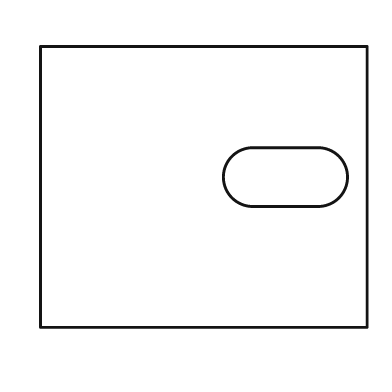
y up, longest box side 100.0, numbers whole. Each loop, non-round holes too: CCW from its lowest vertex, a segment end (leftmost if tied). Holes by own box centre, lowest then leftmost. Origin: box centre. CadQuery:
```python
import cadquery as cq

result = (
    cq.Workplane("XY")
    .moveTo(-50.0, -43.0)
    .lineTo(50.0, -43.0)
    .lineTo(50.0, 43.0)
    .lineTo(-50.0, 43.0)
    .close()
    .moveTo(15.0, -6.0)
    .lineTo(35.0, -6.0)
    .threePointArc((44.0, 3.0), (35.0, 12.0))
    .lineTo(15.0, 12.0)
    .threePointArc((6.0, 3.0), (15.0, -6.0))
    .close()
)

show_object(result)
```